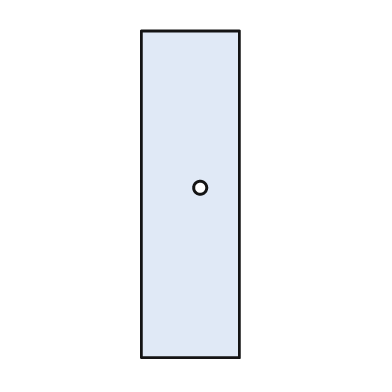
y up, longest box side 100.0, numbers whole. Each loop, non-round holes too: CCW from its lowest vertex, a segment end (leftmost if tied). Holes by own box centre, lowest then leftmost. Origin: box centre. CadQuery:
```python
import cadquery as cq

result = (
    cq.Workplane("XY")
    .moveTo(-15.0, -50.0)
    .lineTo(15.0, -50.0)
    .lineTo(15.0, 50.0)
    .lineTo(-15.0, 50.0)
    .close()
    .moveTo(3.0, 2.0)
    .circle(2.0)
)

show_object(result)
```